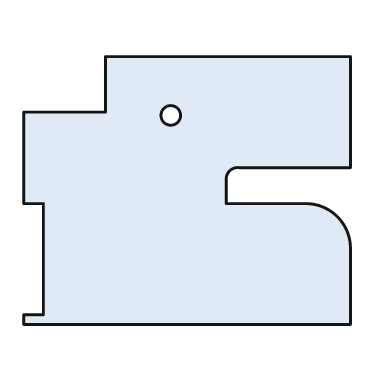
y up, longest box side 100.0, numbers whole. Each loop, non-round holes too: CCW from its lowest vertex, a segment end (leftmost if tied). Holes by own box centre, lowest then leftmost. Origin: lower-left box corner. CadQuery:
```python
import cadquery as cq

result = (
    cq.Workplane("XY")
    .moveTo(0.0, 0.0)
    .lineTo(100.0, 0.0)
    .lineTo(100.0, 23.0)
    .threePointArc((96.0, 33.0), (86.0, 37.0))
    .lineTo(62.0, 37.0)
    .lineTo(62.0, 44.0)
    .threePointArc((63.0, 47.0), (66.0, 48.0))
    .lineTo(100.0, 48.0)
    .lineTo(100.0, 82.0)
    .lineTo(25.0, 82.0)
    .lineTo(25.0, 65.0)
    .lineTo(0.0, 65.0)
    .lineTo(0.0, 37.0)
    .lineTo(6.0, 37.0)
    .lineTo(6.0, 3.0)
    .lineTo(0.0, 3.0)
    .close()
    .moveTo(45.0, 64.0)
    .circle(3.0)
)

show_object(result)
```